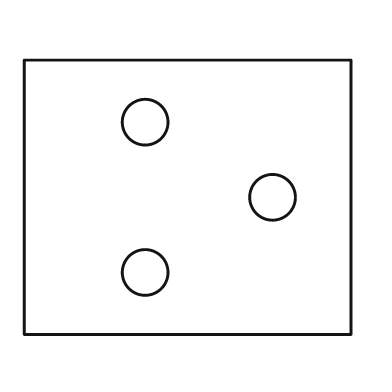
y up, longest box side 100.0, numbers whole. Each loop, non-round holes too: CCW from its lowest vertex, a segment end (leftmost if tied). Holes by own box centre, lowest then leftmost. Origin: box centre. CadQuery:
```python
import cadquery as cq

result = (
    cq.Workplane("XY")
    .moveTo(-50.0, -42.0)
    .lineTo(50.0, -42.0)
    .lineTo(50.0, 42.0)
    .lineTo(-50.0, 42.0)
    .close()
    .moveTo(-13.0, -23.0)
    .circle(7.0)
    .moveTo(26.0, 0.0)
    .circle(7.0)
    .moveTo(-13.0, 23.0)
    .circle(7.0)
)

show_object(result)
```